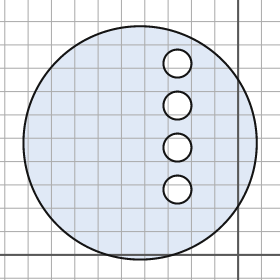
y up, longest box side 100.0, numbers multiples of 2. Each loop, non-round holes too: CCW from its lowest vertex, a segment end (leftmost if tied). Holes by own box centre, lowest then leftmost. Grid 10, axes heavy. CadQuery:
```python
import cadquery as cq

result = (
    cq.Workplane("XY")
    .moveTo(-42.0, 48.0)
    .circle(50.0)
    .moveTo(-26.0, 28.0)
    .circle(6.0)
    .moveTo(-26.0, 46.0)
    .circle(6.0)
    .moveTo(-26.0, 64.0)
    .circle(6.0)
    .moveTo(-26.0, 82.0)
    .circle(6.0)
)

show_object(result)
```